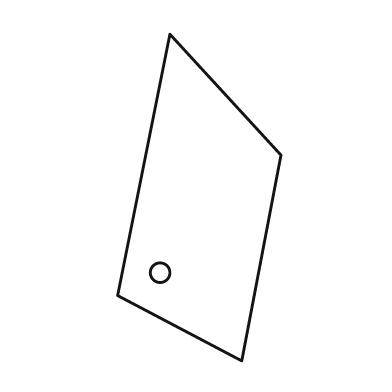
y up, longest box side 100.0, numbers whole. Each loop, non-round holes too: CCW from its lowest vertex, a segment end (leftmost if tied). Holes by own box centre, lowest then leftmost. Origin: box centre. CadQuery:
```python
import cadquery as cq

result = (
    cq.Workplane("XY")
    .moveTo(13.0, -50.0)
    .lineTo(25.0, 13.0)
    .lineTo(-9.0, 50.0)
    .lineTo(-25.0, -30.0)
    .close()
    .moveTo(-12.0, -23.0)
    .circle(3.0)
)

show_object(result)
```